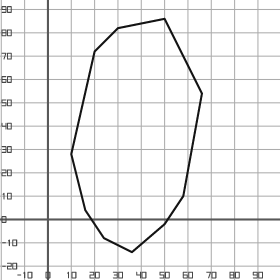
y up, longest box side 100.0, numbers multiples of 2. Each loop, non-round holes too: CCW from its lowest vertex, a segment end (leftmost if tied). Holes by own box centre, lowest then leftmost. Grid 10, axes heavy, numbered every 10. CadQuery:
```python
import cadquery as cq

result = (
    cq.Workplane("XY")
    .moveTo(36.0, -14.0)
    .lineTo(50.0, -2.0)
    .lineTo(58.0, 10.0)
    .lineTo(66.0, 54.0)
    .lineTo(50.0, 86.0)
    .lineTo(30.0, 82.0)
    .lineTo(20.0, 72.0)
    .lineTo(10.0, 28.0)
    .lineTo(16.0, 4.0)
    .lineTo(24.0, -8.0)
    .close()
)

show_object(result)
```